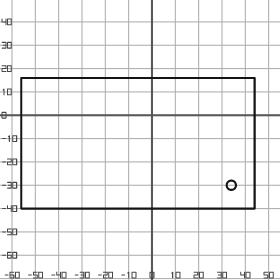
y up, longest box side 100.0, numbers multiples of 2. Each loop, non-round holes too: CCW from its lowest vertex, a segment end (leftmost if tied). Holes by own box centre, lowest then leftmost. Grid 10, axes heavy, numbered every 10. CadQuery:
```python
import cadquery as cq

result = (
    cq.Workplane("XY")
    .moveTo(-56.0, -40.0)
    .lineTo(44.0, -40.0)
    .lineTo(44.0, 16.0)
    .lineTo(-56.0, 16.0)
    .close()
    .moveTo(34.0, -30.0)
    .circle(2.0)
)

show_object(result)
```